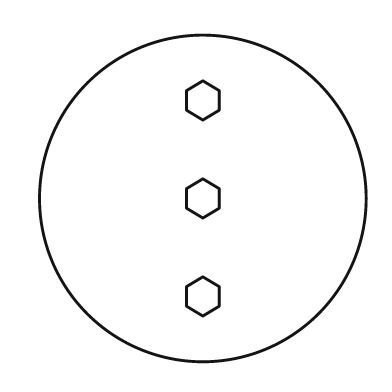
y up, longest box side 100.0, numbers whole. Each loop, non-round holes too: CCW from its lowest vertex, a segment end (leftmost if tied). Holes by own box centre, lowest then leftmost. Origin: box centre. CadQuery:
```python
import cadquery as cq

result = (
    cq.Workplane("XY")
    .moveTo(0.0, 0.0)
    .circle(50.0)
    .moveTo(0.0, -36.0)
    .lineTo(5.0, -33.0)
    .lineTo(5.0, -27.0)
    .lineTo(0.0, -24.0)
    .lineTo(-5.0, -27.0)
    .lineTo(-5.0, -33.0)
    .close()
    .moveTo(0.0, -6.0)
    .lineTo(5.0, -3.0)
    .lineTo(5.0, 3.0)
    .lineTo(0.0, 6.0)
    .lineTo(-5.0, 3.0)
    .lineTo(-5.0, -3.0)
    .close()
    .moveTo(0.0, 24.0)
    .lineTo(5.0, 27.0)
    .lineTo(5.0, 33.0)
    .lineTo(0.0, 36.0)
    .lineTo(-5.0, 33.0)
    .lineTo(-5.0, 27.0)
    .close()
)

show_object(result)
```